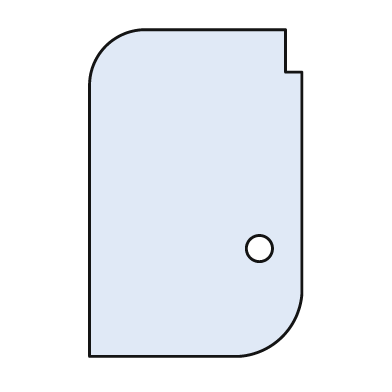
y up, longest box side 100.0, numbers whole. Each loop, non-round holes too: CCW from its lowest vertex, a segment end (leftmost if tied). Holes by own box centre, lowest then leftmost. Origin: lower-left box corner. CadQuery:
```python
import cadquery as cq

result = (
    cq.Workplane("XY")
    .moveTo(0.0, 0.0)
    .lineTo(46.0, 0.0)
    .threePointArc((59.0, 6.0), (65.0, 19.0))
    .lineTo(65.0, 87.0)
    .lineTo(60.0, 87.0)
    .lineTo(60.0, 100.0)
    .lineTo(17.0, 100.0)
    .threePointArc((5.0, 95.0), (0.0, 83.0))
    .close()
    .moveTo(52.0, 33.0)
    .circle(4.0)
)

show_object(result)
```